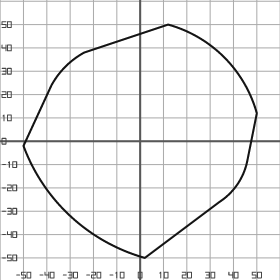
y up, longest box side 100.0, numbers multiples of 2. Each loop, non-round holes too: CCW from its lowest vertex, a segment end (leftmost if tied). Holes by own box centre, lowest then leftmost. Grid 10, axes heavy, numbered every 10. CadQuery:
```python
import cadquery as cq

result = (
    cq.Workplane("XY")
    .moveTo(2.0, -50.0)
    .lineTo(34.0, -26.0)
    .threePointArc((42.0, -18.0), (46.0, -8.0))
    .lineTo(50.0, 12.0)
    .threePointArc((36.0, 36.0), (12.0, 50.0))
    .lineTo(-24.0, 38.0)
    .threePointArc((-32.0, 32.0), (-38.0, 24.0))
    .lineTo(-50.0, -2.0)
    .threePointArc((-30.0, -32.0), (2.0, -50.0))
    .close()
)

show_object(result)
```